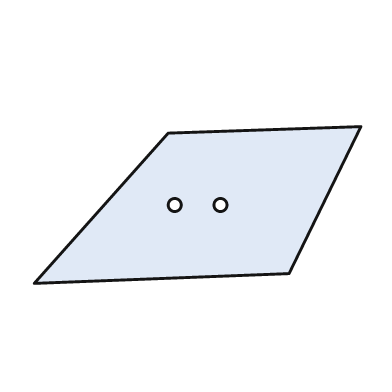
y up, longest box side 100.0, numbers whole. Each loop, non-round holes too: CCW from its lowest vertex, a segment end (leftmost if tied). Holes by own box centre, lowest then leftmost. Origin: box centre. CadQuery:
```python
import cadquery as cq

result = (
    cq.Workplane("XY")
    .moveTo(-50.0, -24.0)
    .lineTo(28.0, -21.0)
    .lineTo(50.0, 24.0)
    .lineTo(-9.0, 22.0)
    .close()
    .moveTo(-7.0, 0.0)
    .circle(2.0)
    .moveTo(7.0, 0.0)
    .circle(2.0)
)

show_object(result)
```